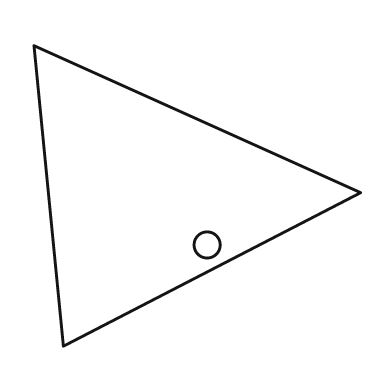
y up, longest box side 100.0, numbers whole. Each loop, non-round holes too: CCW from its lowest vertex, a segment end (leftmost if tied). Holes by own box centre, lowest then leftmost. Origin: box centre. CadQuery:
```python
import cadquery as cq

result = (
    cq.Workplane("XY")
    .moveTo(-41.0, -46.0)
    .lineTo(50.0, 1.0)
    .lineTo(-50.0, 46.0)
    .close()
    .moveTo(3.0, -15.0)
    .circle(4.0)
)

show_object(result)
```